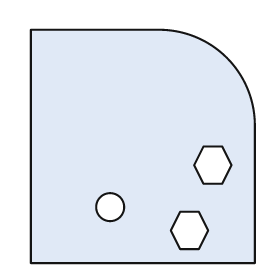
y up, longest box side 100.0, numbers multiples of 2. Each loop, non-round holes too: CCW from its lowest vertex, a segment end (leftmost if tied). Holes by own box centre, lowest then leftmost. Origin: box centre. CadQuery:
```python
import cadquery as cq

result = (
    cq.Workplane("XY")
    .moveTo(-48.0, -50.0)
    .lineTo(48.0, -50.0)
    .lineTo(48.0, 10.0)
    .threePointArc((36.0, 38.0), (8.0, 50.0))
    .lineTo(-48.0, 50.0)
    .close()
    .moveTo(16.0, -44.0)
    .lineTo(24.0, -44.0)
    .lineTo(28.0, -36.0)
    .lineTo(24.0, -28.0)
    .lineTo(16.0, -28.0)
    .lineTo(12.0, -36.0)
    .close()
    .moveTo(-14.0, -26.0)
    .circle(6.0)
    .moveTo(26.0, -16.0)
    .lineTo(34.0, -16.0)
    .lineTo(38.0, -8.0)
    .lineTo(34.0, 0.0)
    .lineTo(26.0, 0.0)
    .lineTo(22.0, -8.0)
    .close()
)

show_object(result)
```